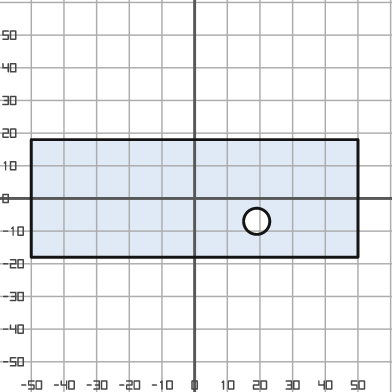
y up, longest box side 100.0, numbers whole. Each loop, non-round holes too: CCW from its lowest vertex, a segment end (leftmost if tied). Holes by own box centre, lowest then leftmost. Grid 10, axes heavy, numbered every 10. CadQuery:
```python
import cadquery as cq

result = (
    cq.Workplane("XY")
    .moveTo(-50.0, -18.0)
    .lineTo(50.0, -18.0)
    .lineTo(50.0, 18.0)
    .lineTo(-50.0, 18.0)
    .close()
    .moveTo(19.0, -7.0)
    .circle(4.0)
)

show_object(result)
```